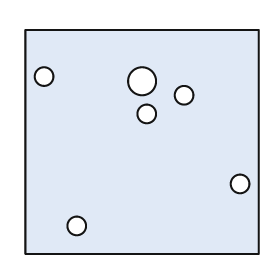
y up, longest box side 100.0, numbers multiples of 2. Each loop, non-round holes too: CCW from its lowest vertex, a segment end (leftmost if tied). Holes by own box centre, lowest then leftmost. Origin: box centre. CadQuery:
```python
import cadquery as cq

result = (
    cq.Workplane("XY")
    .moveTo(-50.0, -48.0)
    .lineTo(50.0, -48.0)
    .lineTo(50.0, 48.0)
    .lineTo(-50.0, 48.0)
    .close()
    .moveTo(-28.0, -36.0)
    .circle(4.0)
    .moveTo(42.0, -18.0)
    .circle(4.0)
    .moveTo(2.0, 12.0)
    .circle(4.0)
    .moveTo(18.0, 20.0)
    .circle(4.0)
    .moveTo(0.0, 26.0)
    .circle(6.0)
    .moveTo(-42.0, 28.0)
    .circle(4.0)
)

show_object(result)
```